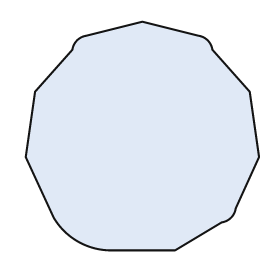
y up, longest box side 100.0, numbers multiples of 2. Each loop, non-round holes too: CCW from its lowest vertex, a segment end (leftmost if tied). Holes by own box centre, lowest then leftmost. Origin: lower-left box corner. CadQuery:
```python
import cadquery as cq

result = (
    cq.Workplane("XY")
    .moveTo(36.0, 0.0)
    .lineTo(64.0, 0.0)
    .lineTo(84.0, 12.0)
    .threePointArc((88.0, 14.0), (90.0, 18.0))
    .lineTo(100.0, 40.0)
    .lineTo(96.0, 68.0)
    .lineTo(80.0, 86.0)
    .threePointArc((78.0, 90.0), (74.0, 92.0))
    .lineTo(50.0, 98.0)
    .lineTo(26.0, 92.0)
    .threePointArc((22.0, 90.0), (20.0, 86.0))
    .lineTo(4.0, 68.0)
    .lineTo(0.0, 40.0)
    .lineTo(12.0, 14.0)
    .threePointArc((22.0, 4.0), (36.0, 0.0))
    .close()
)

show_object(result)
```